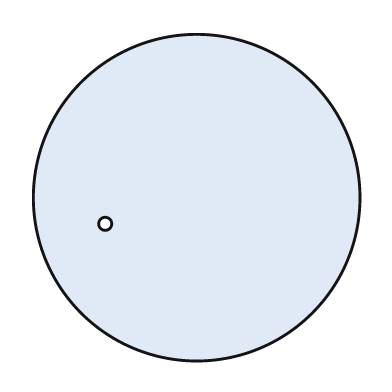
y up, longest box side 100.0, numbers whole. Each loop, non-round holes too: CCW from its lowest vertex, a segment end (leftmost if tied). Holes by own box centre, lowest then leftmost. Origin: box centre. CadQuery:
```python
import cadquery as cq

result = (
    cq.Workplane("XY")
    .moveTo(0.0, 0.0)
    .circle(50.0)
    .moveTo(-28.0, -8.0)
    .circle(2.0)
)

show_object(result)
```